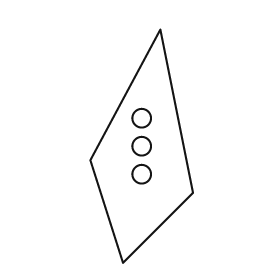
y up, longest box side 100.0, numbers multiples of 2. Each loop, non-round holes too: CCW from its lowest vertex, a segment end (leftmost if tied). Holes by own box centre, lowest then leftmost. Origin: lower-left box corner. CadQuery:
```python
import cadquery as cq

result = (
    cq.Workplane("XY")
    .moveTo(14.0, 0.0)
    .lineTo(44.0, 30.0)
    .lineTo(30.0, 100.0)
    .lineTo(0.0, 44.0)
    .close()
    .moveTo(22.0, 38.0)
    .circle(4.0)
    .moveTo(22.0, 50.0)
    .circle(4.0)
    .moveTo(22.0, 62.0)
    .circle(4.0)
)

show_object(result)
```